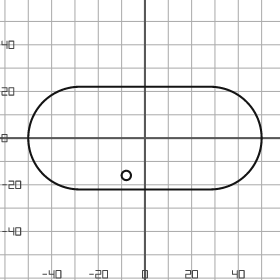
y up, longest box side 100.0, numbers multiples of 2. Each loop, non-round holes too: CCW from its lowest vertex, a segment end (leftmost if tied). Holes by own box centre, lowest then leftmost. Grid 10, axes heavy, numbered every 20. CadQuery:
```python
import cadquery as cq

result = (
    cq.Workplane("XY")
    .moveTo(-28.0, -22.0)
    .lineTo(28.0, -22.0)
    .threePointArc((50.0, 0.0), (28.0, 22.0))
    .lineTo(-28.0, 22.0)
    .threePointArc((-50.0, 0.0), (-28.0, -22.0))
    .close()
    .moveTo(-8.0, -16.0)
    .circle(2.0)
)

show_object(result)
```